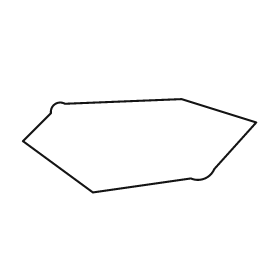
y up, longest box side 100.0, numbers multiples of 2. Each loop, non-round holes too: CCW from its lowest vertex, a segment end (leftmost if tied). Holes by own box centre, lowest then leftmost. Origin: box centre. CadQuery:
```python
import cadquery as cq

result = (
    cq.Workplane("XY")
    .moveTo(-20.0, -20.0)
    .lineTo(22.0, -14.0)
    .threePointArc((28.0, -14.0), (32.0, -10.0))
    .lineTo(50.0, 10.0)
    .lineTo(18.0, 20.0)
    .lineTo(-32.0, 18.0)
    .threePointArc((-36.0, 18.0), (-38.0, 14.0))
    .lineTo(-50.0, 2.0)
    .close()
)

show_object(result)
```